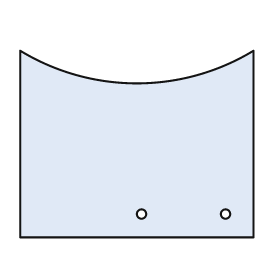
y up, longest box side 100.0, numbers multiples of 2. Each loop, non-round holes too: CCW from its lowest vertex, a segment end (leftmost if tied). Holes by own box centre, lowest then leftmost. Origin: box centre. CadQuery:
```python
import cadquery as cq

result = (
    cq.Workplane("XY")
    .moveTo(-50.0, -40.0)
    .lineTo(50.0, -40.0)
    .lineTo(50.0, 40.0)
    .threePointArc((0.0, 26.0), (-50.0, 40.0))
    .close()
    .moveTo(2.0, -30.0)
    .circle(2.0)
    .moveTo(38.0, -30.0)
    .circle(2.0)
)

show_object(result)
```